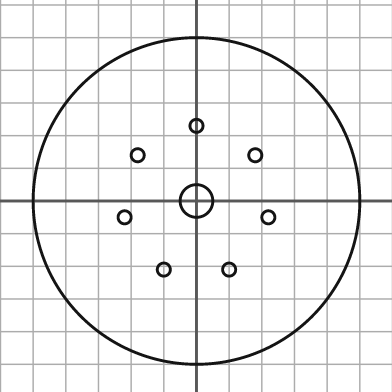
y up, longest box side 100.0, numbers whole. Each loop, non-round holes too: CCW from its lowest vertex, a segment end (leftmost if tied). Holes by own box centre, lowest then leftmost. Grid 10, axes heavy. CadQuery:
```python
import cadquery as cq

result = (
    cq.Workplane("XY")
    .moveTo(0.0, 0.0)
    .circle(50.0)
    .moveTo(-10.0, -21.0)
    .circle(2.0)
    .moveTo(10.0, -21.0)
    .circle(2.0)
    .moveTo(-22.0, -5.0)
    .circle(2.0)
    .moveTo(22.0, -5.0)
    .circle(2.0)
    .moveTo(0.0, 0.0)
    .circle(5.0)
    .moveTo(-18.0, 14.0)
    .circle(2.0)
    .moveTo(18.0, 14.0)
    .circle(2.0)
    .moveTo(0.0, 23.0)
    .circle(2.0)
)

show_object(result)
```